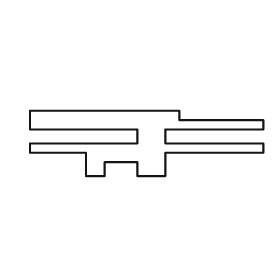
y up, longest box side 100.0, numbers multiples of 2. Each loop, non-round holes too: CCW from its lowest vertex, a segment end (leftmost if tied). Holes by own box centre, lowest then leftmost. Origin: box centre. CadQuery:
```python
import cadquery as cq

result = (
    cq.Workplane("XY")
    .moveTo(-26.0, -14.0)
    .lineTo(-18.0, -14.0)
    .lineTo(-18.0, -8.0)
    .lineTo(-4.0, -8.0)
    .lineTo(-4.0, -14.0)
    .lineTo(8.0, -14.0)
    .lineTo(8.0, -4.0)
    .lineTo(50.0, -4.0)
    .lineTo(50.0, 0.0)
    .lineTo(8.0, 0.0)
    .lineTo(8.0, 6.0)
    .lineTo(50.0, 6.0)
    .lineTo(50.0, 10.0)
    .lineTo(14.0, 10.0)
    .lineTo(14.0, 14.0)
    .lineTo(-50.0, 14.0)
    .lineTo(-50.0, 6.0)
    .lineTo(-4.0, 6.0)
    .lineTo(-4.0, 0.0)
    .lineTo(-50.0, 0.0)
    .lineTo(-50.0, -4.0)
    .lineTo(-26.0, -4.0)
    .close()
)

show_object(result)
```